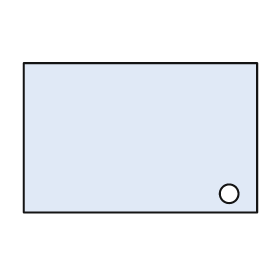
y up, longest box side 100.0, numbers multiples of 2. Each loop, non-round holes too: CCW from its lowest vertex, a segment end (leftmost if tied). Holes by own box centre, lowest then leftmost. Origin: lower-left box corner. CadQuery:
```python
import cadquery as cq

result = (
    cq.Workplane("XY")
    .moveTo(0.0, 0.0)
    .lineTo(100.0, 0.0)
    .lineTo(100.0, 64.0)
    .lineTo(0.0, 64.0)
    .close()
    .moveTo(88.0, 8.0)
    .circle(4.0)
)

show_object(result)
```